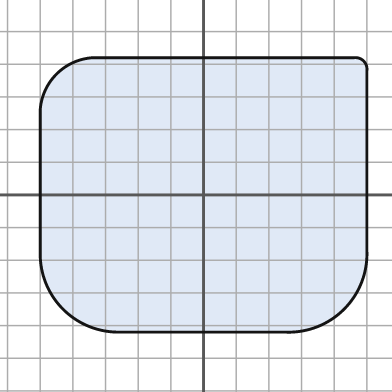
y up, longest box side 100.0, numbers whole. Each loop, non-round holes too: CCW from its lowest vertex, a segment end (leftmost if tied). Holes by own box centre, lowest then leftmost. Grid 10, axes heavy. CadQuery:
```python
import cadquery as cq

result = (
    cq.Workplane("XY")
    .moveTo(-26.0, -42.0)
    .lineTo(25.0, -42.0)
    .threePointArc((43.0, -35.0), (50.0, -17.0))
    .lineTo(50.0, 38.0)
    .threePointArc((49.0, 41.0), (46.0, 42.0))
    .lineTo(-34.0, 42.0)
    .threePointArc((-45.0, 37.0), (-50.0, 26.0))
    .lineTo(-50.0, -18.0)
    .threePointArc((-43.0, -35.0), (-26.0, -42.0))
    .close()
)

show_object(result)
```